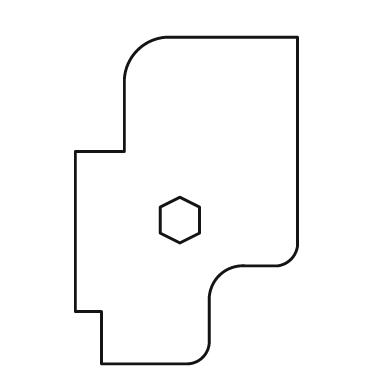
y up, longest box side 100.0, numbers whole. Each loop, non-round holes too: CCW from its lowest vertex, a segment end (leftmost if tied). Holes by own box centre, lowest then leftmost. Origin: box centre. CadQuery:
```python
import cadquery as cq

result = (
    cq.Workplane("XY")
    .moveTo(-26.0, -50.0)
    .lineTo(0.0, -50.0)
    .threePointArc((5.0, -48.0), (7.0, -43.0))
    .lineTo(7.0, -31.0)
    .threePointArc((10.0, -23.0), (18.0, -20.0))
    .lineTo(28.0, -20.0)
    .threePointArc((32.0, -18.0), (34.0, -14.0))
    .lineTo(34.0, 50.0)
    .lineTo(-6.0, 50.0)
    .threePointArc((-15.0, 46.0), (-19.0, 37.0))
    .lineTo(-19.0, 15.0)
    .lineTo(-34.0, 15.0)
    .lineTo(-34.0, -34.0)
    .lineTo(-26.0, -34.0)
    .close()
    .moveTo(-2.0, -13.0)
    .lineTo(4.0, -10.0)
    .lineTo(4.0, -2.0)
    .lineTo(-2.0, 1.0)
    .lineTo(-8.0, -2.0)
    .lineTo(-8.0, -10.0)
    .close()
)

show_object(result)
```